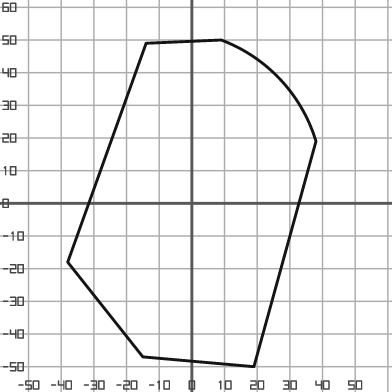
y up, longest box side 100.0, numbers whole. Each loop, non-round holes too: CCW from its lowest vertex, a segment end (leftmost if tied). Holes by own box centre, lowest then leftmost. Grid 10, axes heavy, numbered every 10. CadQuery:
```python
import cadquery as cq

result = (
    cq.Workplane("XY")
    .moveTo(19.0, -50.0)
    .lineTo(38.0, 19.0)
    .threePointArc((27.0, 38.0), (9.0, 50.0))
    .lineTo(-14.0, 49.0)
    .lineTo(-38.0, -18.0)
    .lineTo(-15.0, -47.0)
    .close()
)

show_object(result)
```